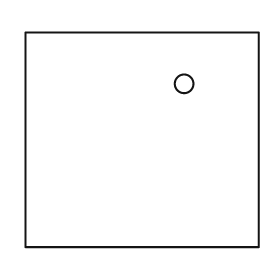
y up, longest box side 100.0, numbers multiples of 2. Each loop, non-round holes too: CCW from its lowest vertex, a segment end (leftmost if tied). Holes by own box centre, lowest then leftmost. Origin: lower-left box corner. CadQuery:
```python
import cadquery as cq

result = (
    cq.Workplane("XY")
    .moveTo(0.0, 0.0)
    .lineTo(100.0, 0.0)
    .lineTo(100.0, 92.0)
    .lineTo(0.0, 92.0)
    .close()
    .moveTo(68.0, 70.0)
    .circle(4.0)
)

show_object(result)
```